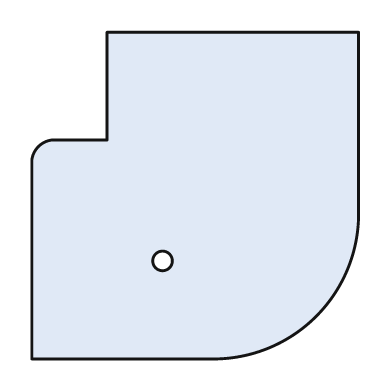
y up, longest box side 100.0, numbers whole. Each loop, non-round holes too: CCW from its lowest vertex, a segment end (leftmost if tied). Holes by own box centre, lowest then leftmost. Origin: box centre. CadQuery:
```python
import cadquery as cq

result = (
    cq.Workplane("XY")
    .moveTo(-50.0, -50.0)
    .lineTo(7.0, -50.0)
    .threePointArc((37.0, -37.0), (50.0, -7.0))
    .lineTo(50.0, 50.0)
    .lineTo(-27.0, 50.0)
    .lineTo(-27.0, 17.0)
    .lineTo(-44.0, 17.0)
    .threePointArc((-48.0, 15.0), (-50.0, 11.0))
    .close()
    .moveTo(-10.0, -20.0)
    .circle(3.0)
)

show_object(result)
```